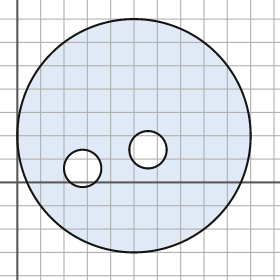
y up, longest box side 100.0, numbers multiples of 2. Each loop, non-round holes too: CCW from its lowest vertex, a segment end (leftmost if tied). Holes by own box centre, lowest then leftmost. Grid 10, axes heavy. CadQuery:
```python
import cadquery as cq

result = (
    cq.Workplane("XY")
    .moveTo(50.0, 20.0)
    .circle(50.0)
    .moveTo(28.0, 6.0)
    .circle(8.0)
    .moveTo(56.0, 14.0)
    .circle(8.0)
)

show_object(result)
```